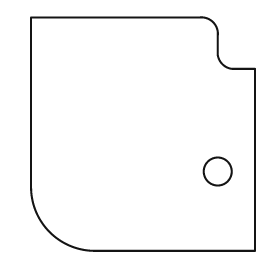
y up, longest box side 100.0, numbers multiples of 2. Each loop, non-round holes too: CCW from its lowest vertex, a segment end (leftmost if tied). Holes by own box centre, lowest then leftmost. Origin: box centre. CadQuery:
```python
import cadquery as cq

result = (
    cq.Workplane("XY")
    .moveTo(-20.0, -50.0)
    .lineTo(48.0, -50.0)
    .lineTo(48.0, 28.0)
    .lineTo(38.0, 28.0)
    .threePointArc((34.0, 30.0), (32.0, 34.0))
    .lineTo(32.0, 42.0)
    .threePointArc((30.0, 48.0), (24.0, 50.0))
    .lineTo(-48.0, 50.0)
    .lineTo(-48.0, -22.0)
    .threePointArc((-40.0, -42.0), (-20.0, -50.0))
    .close()
    .moveTo(32.0, -16.0)
    .circle(6.0)
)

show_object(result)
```